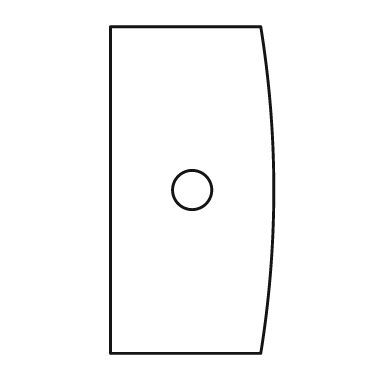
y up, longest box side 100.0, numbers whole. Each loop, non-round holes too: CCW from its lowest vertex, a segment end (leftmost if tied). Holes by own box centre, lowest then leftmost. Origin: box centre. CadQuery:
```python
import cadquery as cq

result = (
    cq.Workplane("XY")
    .moveTo(-25.0, -50.0)
    .lineTo(21.0, -50.0)
    .threePointArc((25.0, 0.0), (21.0, 50.0))
    .lineTo(-25.0, 50.0)
    .close()
    .moveTo(0.0, 0.0)
    .circle(6.0)
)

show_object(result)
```